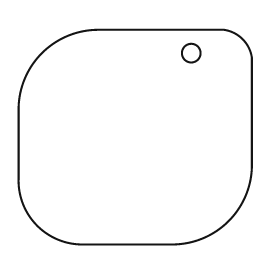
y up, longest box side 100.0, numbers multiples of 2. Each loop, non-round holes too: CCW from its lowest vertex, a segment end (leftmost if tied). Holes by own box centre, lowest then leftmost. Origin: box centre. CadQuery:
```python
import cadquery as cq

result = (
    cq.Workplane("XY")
    .moveTo(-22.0, -46.0)
    .lineTo(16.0, -46.0)
    .threePointArc((40.0, -36.0), (50.0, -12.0))
    .lineTo(50.0, 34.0)
    .threePointArc((46.0, 42.0), (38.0, 46.0))
    .lineTo(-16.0, 46.0)
    .threePointArc((-40.0, 36.0), (-50.0, 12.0))
    .lineTo(-50.0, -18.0)
    .threePointArc((-42.0, -38.0), (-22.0, -46.0))
    .close()
    .moveTo(24.0, 36.0)
    .circle(4.0)
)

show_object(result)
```